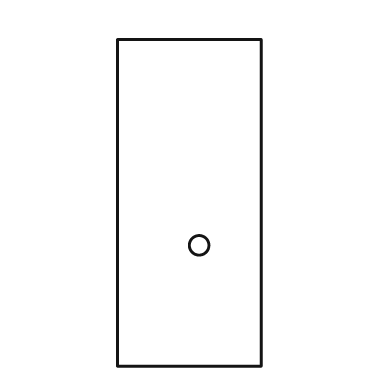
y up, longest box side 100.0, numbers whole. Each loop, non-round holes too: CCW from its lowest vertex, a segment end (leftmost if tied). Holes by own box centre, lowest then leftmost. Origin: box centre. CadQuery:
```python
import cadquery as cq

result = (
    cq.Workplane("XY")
    .moveTo(-22.0, -50.0)
    .lineTo(22.0, -50.0)
    .lineTo(22.0, 50.0)
    .lineTo(-22.0, 50.0)
    .close()
    .moveTo(3.0, -13.0)
    .circle(3.0)
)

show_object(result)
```